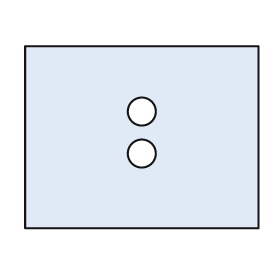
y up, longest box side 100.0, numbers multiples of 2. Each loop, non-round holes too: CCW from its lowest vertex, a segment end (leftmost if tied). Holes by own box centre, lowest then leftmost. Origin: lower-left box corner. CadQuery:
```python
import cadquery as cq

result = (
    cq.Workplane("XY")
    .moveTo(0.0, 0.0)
    .lineTo(100.0, 0.0)
    .lineTo(100.0, 78.0)
    .lineTo(0.0, 78.0)
    .close()
    .moveTo(50.0, 32.0)
    .circle(6.0)
    .moveTo(50.0, 50.0)
    .circle(6.0)
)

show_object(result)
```